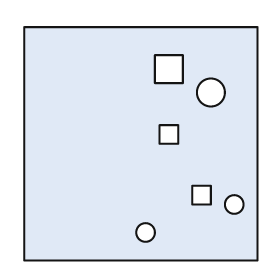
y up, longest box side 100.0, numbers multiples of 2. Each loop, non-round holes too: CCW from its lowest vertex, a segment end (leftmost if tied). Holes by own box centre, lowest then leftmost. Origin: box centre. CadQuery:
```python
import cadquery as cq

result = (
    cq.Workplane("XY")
    .moveTo(-50.0, -50.0)
    .lineTo(50.0, -50.0)
    .lineTo(50.0, 50.0)
    .lineTo(-50.0, 50.0)
    .close()
    .moveTo(2.0, -38.0)
    .circle(4.0)
    .moveTo(40.0, -26.0)
    .circle(4.0)
    .moveTo(22.0, -26.0)
    .lineTo(30.0, -26.0)
    .lineTo(30.0, -18.0)
    .lineTo(22.0, -18.0)
    .close()
    .moveTo(8.0, 0.0)
    .lineTo(16.0, 0.0)
    .lineTo(16.0, 8.0)
    .lineTo(8.0, 8.0)
    .close()
    .moveTo(30.0, 22.0)
    .circle(6.0)
    .moveTo(6.0, 26.0)
    .lineTo(18.0, 26.0)
    .lineTo(18.0, 38.0)
    .lineTo(6.0, 38.0)
    .close()
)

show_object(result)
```